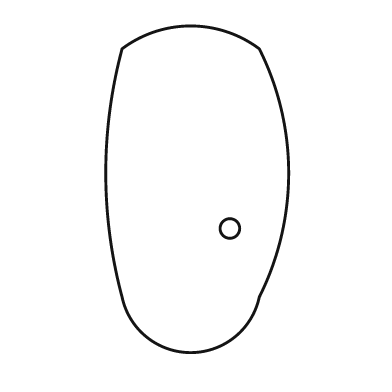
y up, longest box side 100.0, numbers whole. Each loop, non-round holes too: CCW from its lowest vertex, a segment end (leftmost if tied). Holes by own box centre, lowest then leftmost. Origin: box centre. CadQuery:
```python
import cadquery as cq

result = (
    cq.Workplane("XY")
    .moveTo(-23.0, -33.0)
    .threePointArc((-2.0, -50.0), (19.0, -33.0))
    .threePointArc((28.0, 5.0), (19.0, 43.0))
    .threePointArc((-2.0, 50.0), (-23.0, 43.0))
    .threePointArc((-28.0, 5.0), (-23.0, -33.0))
    .close()
    .moveTo(10.0, -12.0)
    .circle(3.0)
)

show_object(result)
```